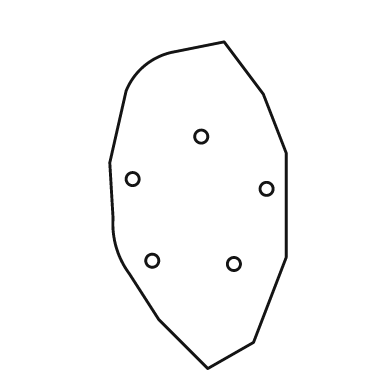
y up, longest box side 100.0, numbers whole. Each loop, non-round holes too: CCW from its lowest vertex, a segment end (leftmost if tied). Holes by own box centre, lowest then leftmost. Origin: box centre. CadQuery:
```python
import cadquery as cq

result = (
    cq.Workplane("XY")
    .moveTo(3.0, -50.0)
    .lineTo(17.0, -42.0)
    .lineTo(27.0, -16.0)
    .lineTo(27.0, 16.0)
    .lineTo(20.0, 34.0)
    .lineTo(8.0, 50.0)
    .lineTo(-7.0, 47.0)
    .threePointArc((-16.0, 43.0), (-22.0, 35.0))
    .lineTo(-27.0, 13.0)
    .lineTo(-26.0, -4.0)
    .threePointArc((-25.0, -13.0), (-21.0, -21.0))
    .lineTo(-12.0, -35.0)
    .close()
    .moveTo(11.0, -18.0)
    .circle(2.0)
    .moveTo(-14.0, -17.0)
    .circle(2.0)
    .moveTo(21.0, 5.0)
    .circle(2.0)
    .moveTo(-20.0, 8.0)
    .circle(2.0)
    .moveTo(1.0, 21.0)
    .circle(2.0)
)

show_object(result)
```